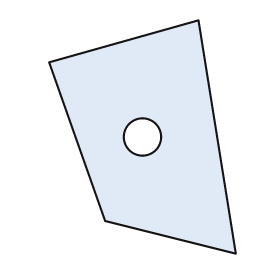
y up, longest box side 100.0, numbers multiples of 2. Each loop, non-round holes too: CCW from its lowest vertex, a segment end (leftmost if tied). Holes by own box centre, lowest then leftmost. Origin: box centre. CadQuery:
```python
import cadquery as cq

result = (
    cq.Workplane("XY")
    .moveTo(40.0, -50.0)
    .lineTo(24.0, 50.0)
    .lineTo(-40.0, 32.0)
    .lineTo(-16.0, -36.0)
    .close()
    .moveTo(0.0, 0.0)
    .circle(8.0)
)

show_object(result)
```